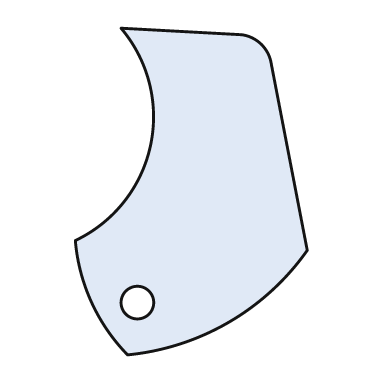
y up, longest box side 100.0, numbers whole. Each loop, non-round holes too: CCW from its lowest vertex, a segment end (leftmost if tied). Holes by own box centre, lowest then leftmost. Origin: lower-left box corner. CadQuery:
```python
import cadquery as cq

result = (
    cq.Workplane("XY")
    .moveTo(16.0, 0.0)
    .threePointArc((47.0, 10.0), (71.0, 32.0))
    .lineTo(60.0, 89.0)
    .threePointArc((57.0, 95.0), (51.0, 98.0))
    .lineTo(14.0, 100.0)
    .threePointArc((23.0, 64.0), (0.0, 35.0))
    .threePointArc((5.0, 16.0), (16.0, 0.0))
    .close()
    .moveTo(19.0, 16.0)
    .circle(5.0)
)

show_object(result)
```